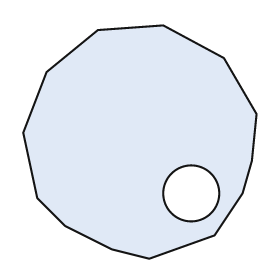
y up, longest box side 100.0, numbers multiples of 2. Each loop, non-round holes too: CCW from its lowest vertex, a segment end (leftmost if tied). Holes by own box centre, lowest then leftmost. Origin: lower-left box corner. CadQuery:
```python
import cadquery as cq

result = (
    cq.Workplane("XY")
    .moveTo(54.0, 0.0)
    .lineTo(82.0, 10.0)
    .lineTo(94.0, 28.0)
    .lineTo(98.0, 42.0)
    .lineTo(100.0, 62.0)
    .lineTo(86.0, 86.0)
    .lineTo(60.0, 100.0)
    .lineTo(32.0, 98.0)
    .lineTo(10.0, 80.0)
    .lineTo(0.0, 54.0)
    .lineTo(6.0, 26.0)
    .lineTo(18.0, 14.0)
    .lineTo(38.0, 4.0)
    .close()
    .moveTo(72.0, 28.0)
    .circle(12.0)
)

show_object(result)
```